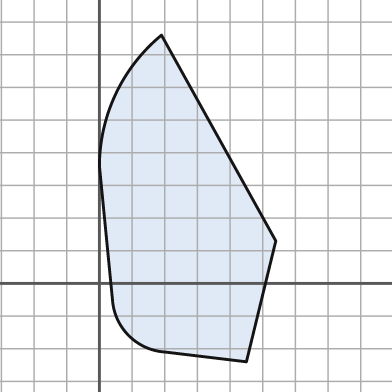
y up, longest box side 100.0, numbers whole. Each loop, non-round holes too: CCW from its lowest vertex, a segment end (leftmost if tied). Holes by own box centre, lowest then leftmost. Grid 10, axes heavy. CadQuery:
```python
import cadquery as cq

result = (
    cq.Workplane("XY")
    .moveTo(45.0, -24.0)
    .lineTo(54.0, 13.0)
    .lineTo(19.0, 76.0)
    .threePointArc((5.0, 58.0), (0.0, 36.0))
    .lineTo(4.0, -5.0)
    .threePointArc((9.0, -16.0), (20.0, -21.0))
    .close()
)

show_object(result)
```